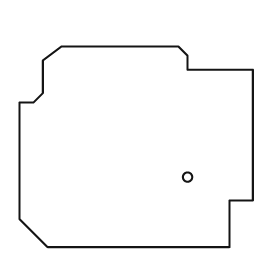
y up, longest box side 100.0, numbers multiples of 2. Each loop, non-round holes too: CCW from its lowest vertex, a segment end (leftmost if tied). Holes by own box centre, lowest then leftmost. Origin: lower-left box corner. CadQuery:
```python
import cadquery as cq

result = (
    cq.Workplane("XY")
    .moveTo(12.0, 0.0)
    .lineTo(90.0, 0.0)
    .lineTo(90.0, 20.0)
    .lineTo(100.0, 20.0)
    .lineTo(100.0, 76.0)
    .lineTo(72.0, 76.0)
    .lineTo(72.0, 82.0)
    .lineTo(68.0, 86.0)
    .lineTo(18.0, 86.0)
    .lineTo(10.0, 80.0)
    .lineTo(10.0, 66.0)
    .lineTo(6.0, 62.0)
    .lineTo(0.0, 62.0)
    .lineTo(0.0, 12.0)
    .close()
    .moveTo(72.0, 30.0)
    .circle(2.0)
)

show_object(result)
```